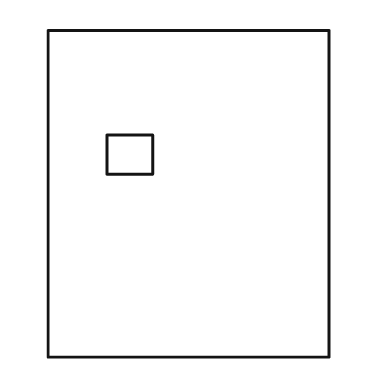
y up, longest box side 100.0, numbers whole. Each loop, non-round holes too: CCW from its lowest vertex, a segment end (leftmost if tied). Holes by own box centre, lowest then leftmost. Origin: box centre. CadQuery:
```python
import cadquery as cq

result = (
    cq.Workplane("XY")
    .moveTo(-43.0, -50.0)
    .lineTo(43.0, -50.0)
    .lineTo(43.0, 50.0)
    .lineTo(-43.0, 50.0)
    .close()
    .moveTo(-25.0, 6.0)
    .lineTo(-11.0, 6.0)
    .lineTo(-11.0, 18.0)
    .lineTo(-25.0, 18.0)
    .close()
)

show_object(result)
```